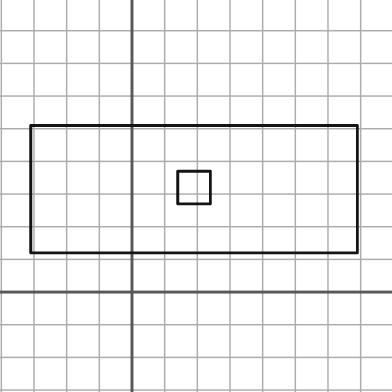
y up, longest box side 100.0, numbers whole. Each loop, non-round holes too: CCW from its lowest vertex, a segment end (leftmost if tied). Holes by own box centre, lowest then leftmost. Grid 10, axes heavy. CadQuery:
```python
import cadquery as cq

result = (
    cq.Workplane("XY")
    .moveTo(-31.0, 12.0)
    .lineTo(69.0, 12.0)
    .lineTo(69.0, 51.0)
    .lineTo(-31.0, 51.0)
    .close()
    .moveTo(14.0, 27.0)
    .lineTo(24.0, 27.0)
    .lineTo(24.0, 37.0)
    .lineTo(14.0, 37.0)
    .close()
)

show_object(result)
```